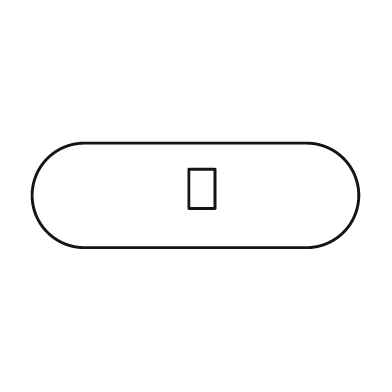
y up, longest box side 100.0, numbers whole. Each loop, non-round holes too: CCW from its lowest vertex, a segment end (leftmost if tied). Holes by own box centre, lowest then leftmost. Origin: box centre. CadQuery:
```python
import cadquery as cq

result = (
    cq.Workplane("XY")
    .moveTo(-34.0, -16.0)
    .lineTo(34.0, -16.0)
    .threePointArc((50.0, 0.0), (34.0, 16.0))
    .lineTo(-34.0, 16.0)
    .threePointArc((-50.0, 0.0), (-34.0, -16.0))
    .close()
    .moveTo(-2.0, -4.0)
    .lineTo(6.0, -4.0)
    .lineTo(6.0, 8.0)
    .lineTo(-2.0, 8.0)
    .close()
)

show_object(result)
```